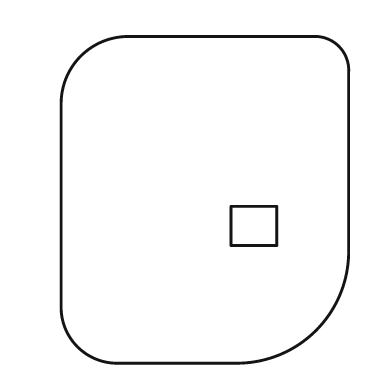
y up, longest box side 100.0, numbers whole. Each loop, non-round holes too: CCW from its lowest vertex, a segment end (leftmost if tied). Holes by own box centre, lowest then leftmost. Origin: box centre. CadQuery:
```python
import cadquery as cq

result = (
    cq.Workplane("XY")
    .moveTo(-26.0, -50.0)
    .lineTo(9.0, -50.0)
    .threePointArc((34.0, -40.0), (44.0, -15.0))
    .lineTo(44.0, 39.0)
    .threePointArc((41.0, 47.0), (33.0, 50.0))
    .lineTo(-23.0, 50.0)
    .threePointArc((-38.0, 44.0), (-44.0, 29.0))
    .lineTo(-44.0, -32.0)
    .threePointArc((-39.0, -45.0), (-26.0, -50.0))
    .close()
    .moveTo(8.0, -14.0)
    .lineTo(22.0, -14.0)
    .lineTo(22.0, -2.0)
    .lineTo(8.0, -2.0)
    .close()
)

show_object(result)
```